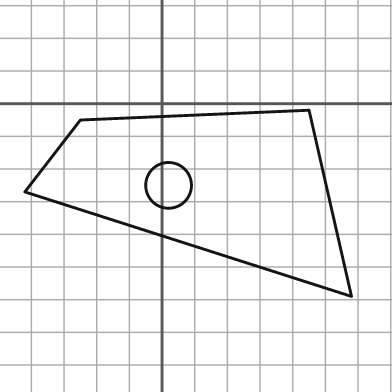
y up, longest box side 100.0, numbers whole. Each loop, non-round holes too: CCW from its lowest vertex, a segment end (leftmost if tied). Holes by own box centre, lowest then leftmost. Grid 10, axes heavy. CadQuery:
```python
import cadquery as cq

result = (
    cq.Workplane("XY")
    .moveTo(58.0, -59.0)
    .lineTo(45.0, -2.0)
    .lineTo(-25.0, -5.0)
    .lineTo(-42.0, -27.0)
    .close()
    .moveTo(2.0, -25.0)
    .circle(7.0)
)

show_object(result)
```